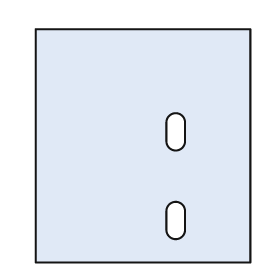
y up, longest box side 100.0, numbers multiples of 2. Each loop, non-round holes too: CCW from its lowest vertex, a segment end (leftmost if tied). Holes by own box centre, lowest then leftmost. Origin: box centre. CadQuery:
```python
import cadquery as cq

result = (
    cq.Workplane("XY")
    .moveTo(-46.0, -50.0)
    .lineTo(46.0, -50.0)
    .lineTo(46.0, 50.0)
    .lineTo(-46.0, 50.0)
    .close()
    .moveTo(10.0, -36.0)
    .threePointArc((14.0, -40.0), (18.0, -36.0))
    .lineTo(18.0, -28.0)
    .threePointArc((14.0, -24.0), (10.0, -28.0))
    .close()
    .moveTo(10.0, 2.0)
    .threePointArc((14.0, -2.0), (18.0, 2.0))
    .lineTo(18.0, 10.0)
    .threePointArc((14.0, 14.0), (10.0, 10.0))
    .close()
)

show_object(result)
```